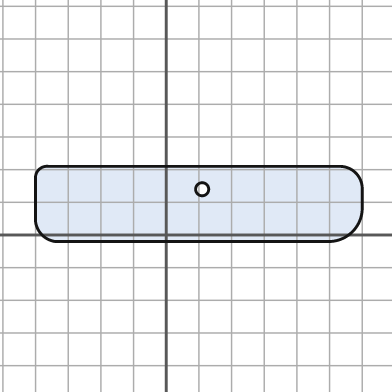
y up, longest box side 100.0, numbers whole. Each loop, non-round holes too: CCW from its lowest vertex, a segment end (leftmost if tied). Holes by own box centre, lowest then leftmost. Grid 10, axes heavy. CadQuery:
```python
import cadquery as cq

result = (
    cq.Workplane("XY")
    .moveTo(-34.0, -2.0)
    .lineTo(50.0, -2.0)
    .threePointArc((57.0, 1.0), (60.0, 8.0))
    .lineTo(60.0, 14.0)
    .threePointArc((58.0, 19.0), (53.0, 21.0))
    .lineTo(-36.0, 21.0)
    .threePointArc((-39.0, 20.0), (-40.0, 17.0))
    .lineTo(-40.0, 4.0)
    .threePointArc((-38.0, 0.0), (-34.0, -2.0))
    .close()
    .moveTo(11.0, 14.0)
    .circle(2.0)
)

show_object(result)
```